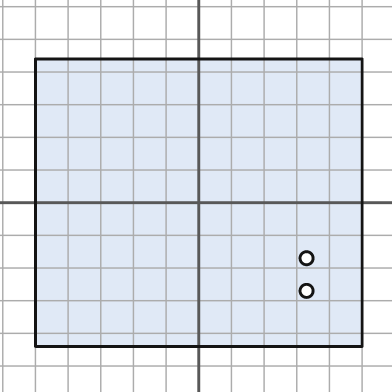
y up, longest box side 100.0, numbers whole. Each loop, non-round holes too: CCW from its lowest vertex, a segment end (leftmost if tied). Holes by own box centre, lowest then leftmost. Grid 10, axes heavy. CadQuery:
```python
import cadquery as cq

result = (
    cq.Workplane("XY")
    .moveTo(-50.0, -44.0)
    .lineTo(50.0, -44.0)
    .lineTo(50.0, 44.0)
    .lineTo(-50.0, 44.0)
    .close()
    .moveTo(33.0, -27.0)
    .circle(2.0)
    .moveTo(33.0, -17.0)
    .circle(2.0)
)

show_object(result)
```